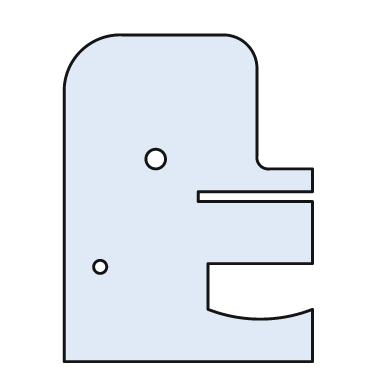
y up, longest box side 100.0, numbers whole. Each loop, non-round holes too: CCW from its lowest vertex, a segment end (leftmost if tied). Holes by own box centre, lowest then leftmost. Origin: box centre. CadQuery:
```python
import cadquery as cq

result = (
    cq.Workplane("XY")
    .moveTo(-38.0, -50.0)
    .lineTo(38.0, -50.0)
    .lineTo(38.0, -34.0)
    .threePointArc((22.0, -37.0), (6.0, -34.0))
    .lineTo(6.0, -20.0)
    .lineTo(38.0, -20.0)
    .lineTo(38.0, -1.0)
    .lineTo(3.0, -1.0)
    .lineTo(3.0, 2.0)
    .lineTo(38.0, 2.0)
    .lineTo(38.0, 9.0)
    .lineTo(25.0, 9.0)
    .threePointArc((22.0, 10.0), (21.0, 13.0))
    .lineTo(21.0, 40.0)
    .threePointArc((18.0, 47.0), (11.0, 50.0))
    .lineTo(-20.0, 50.0)
    .threePointArc((-33.0, 45.0), (-38.0, 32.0))
    .close()
    .moveTo(-27.0, -21.0)
    .circle(2.0)
    .moveTo(-10.0, 12.0)
    .circle(3.0)
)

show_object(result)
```